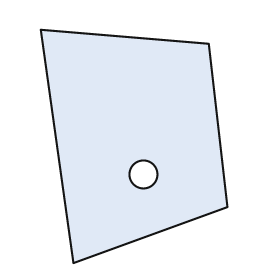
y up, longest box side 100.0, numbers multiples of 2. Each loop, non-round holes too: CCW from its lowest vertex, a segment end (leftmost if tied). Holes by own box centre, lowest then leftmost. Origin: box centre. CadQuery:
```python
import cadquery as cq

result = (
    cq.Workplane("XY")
    .moveTo(-26.0, -50.0)
    .lineTo(40.0, -26.0)
    .lineTo(32.0, 44.0)
    .lineTo(-40.0, 50.0)
    .close()
    .moveTo(4.0, -12.0)
    .circle(6.0)
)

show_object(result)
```